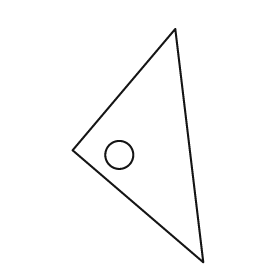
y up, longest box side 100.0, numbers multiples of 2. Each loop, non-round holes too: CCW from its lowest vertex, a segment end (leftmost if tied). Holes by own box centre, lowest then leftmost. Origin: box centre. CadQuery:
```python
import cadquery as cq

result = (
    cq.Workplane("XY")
    .moveTo(28.0, -50.0)
    .lineTo(16.0, 50.0)
    .lineTo(-28.0, -2.0)
    .close()
    .moveTo(-8.0, -4.0)
    .circle(6.0)
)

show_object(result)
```